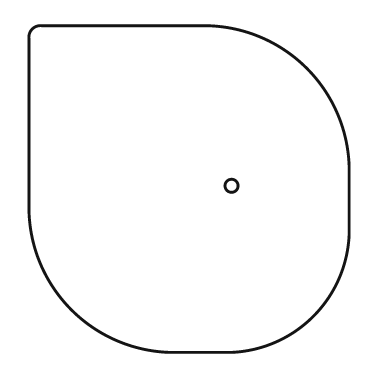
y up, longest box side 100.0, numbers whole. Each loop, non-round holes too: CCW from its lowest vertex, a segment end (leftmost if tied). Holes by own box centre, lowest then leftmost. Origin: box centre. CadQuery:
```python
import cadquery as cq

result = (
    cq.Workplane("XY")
    .moveTo(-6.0, -50.0)
    .lineTo(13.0, -50.0)
    .threePointArc((38.0, -39.0), (49.0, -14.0))
    .lineTo(49.0, 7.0)
    .threePointArc((36.0, 37.0), (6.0, 50.0))
    .lineTo(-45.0, 50.0)
    .threePointArc((-48.0, 49.0), (-49.0, 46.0))
    .lineTo(-49.0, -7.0)
    .threePointArc((-36.0, -37.0), (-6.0, -50.0))
    .close()
    .moveTo(13.0, 1.0)
    .circle(2.0)
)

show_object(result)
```